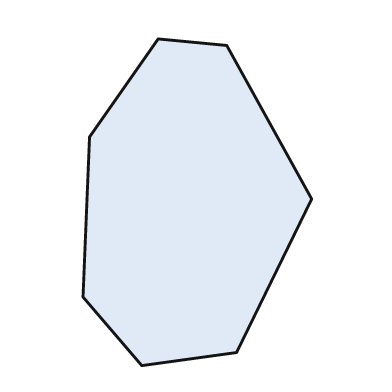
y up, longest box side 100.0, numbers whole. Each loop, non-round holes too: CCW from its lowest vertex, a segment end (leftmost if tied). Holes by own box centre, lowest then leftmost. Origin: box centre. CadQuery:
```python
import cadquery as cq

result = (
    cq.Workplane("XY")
    .moveTo(-17.0, -50.0)
    .lineTo(12.0, -46.0)
    .lineTo(35.0, 1.0)
    .lineTo(9.0, 48.0)
    .lineTo(-12.0, 50.0)
    .lineTo(-33.0, 20.0)
    .lineTo(-35.0, -29.0)
    .close()
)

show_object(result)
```